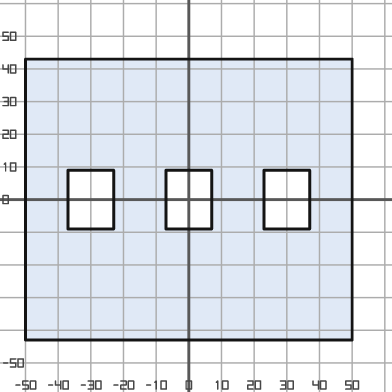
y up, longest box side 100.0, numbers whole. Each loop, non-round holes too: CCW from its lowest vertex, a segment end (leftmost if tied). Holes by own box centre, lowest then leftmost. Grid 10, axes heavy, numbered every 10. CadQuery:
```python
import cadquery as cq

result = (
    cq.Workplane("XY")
    .moveTo(-50.0, -43.0)
    .lineTo(50.0, -43.0)
    .lineTo(50.0, 43.0)
    .lineTo(-50.0, 43.0)
    .close()
    .moveTo(-37.0, -9.0)
    .lineTo(-23.0, -9.0)
    .lineTo(-23.0, 9.0)
    .lineTo(-37.0, 9.0)
    .close()
    .moveTo(-7.0, -9.0)
    .lineTo(7.0, -9.0)
    .lineTo(7.0, 9.0)
    .lineTo(-7.0, 9.0)
    .close()
    .moveTo(23.0, -9.0)
    .lineTo(37.0, -9.0)
    .lineTo(37.0, 9.0)
    .lineTo(23.0, 9.0)
    .close()
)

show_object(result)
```